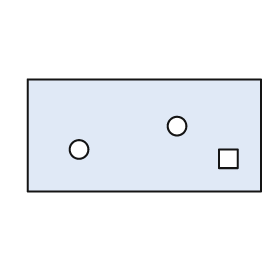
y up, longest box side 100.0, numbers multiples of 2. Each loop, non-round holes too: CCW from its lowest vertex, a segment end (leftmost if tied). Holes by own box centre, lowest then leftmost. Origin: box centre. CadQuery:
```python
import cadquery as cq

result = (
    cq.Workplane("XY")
    .moveTo(-50.0, -24.0)
    .lineTo(50.0, -24.0)
    .lineTo(50.0, 24.0)
    .lineTo(-50.0, 24.0)
    .close()
    .moveTo(32.0, -14.0)
    .lineTo(40.0, -14.0)
    .lineTo(40.0, -6.0)
    .lineTo(32.0, -6.0)
    .close()
    .moveTo(-28.0, -6.0)
    .circle(4.0)
    .moveTo(14.0, 4.0)
    .circle(4.0)
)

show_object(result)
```